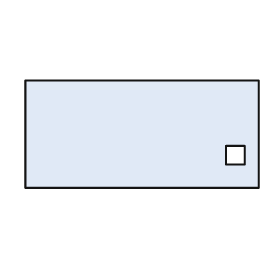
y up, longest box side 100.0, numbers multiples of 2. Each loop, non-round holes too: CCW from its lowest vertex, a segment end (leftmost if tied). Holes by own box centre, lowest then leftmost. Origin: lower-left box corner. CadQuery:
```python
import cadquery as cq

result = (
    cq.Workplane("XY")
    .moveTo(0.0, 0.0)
    .lineTo(100.0, 0.0)
    .lineTo(100.0, 46.0)
    .lineTo(0.0, 46.0)
    .close()
    .moveTo(86.0, 10.0)
    .lineTo(94.0, 10.0)
    .lineTo(94.0, 18.0)
    .lineTo(86.0, 18.0)
    .close()
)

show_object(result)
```